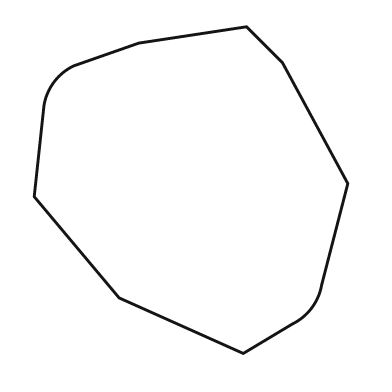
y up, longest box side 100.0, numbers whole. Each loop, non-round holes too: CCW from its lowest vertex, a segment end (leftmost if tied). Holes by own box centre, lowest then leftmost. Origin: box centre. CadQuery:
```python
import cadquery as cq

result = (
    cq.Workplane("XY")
    .moveTo(16.0, -50.0)
    .lineTo(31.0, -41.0)
    .threePointArc((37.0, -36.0), (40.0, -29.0))
    .lineTo(48.0, 2.0)
    .lineTo(28.0, 39.0)
    .lineTo(17.0, 50.0)
    .lineTo(-16.0, 45.0)
    .lineTo(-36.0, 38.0)
    .threePointArc((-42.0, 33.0), (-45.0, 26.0))
    .lineTo(-48.0, -2.0)
    .lineTo(-22.0, -33.0)
    .close()
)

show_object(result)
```